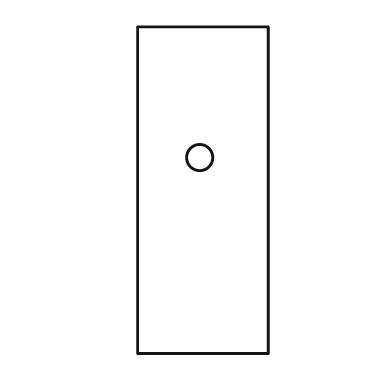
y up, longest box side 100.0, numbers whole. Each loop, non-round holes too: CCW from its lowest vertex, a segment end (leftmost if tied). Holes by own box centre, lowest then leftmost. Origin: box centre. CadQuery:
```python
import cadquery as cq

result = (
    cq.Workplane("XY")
    .moveTo(-20.0, -50.0)
    .lineTo(20.0, -50.0)
    .lineTo(20.0, 50.0)
    .lineTo(-20.0, 50.0)
    .close()
    .moveTo(-1.0, 10.0)
    .circle(4.0)
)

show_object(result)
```